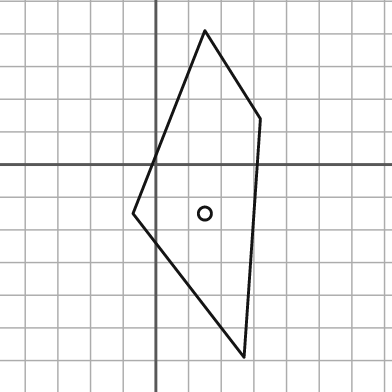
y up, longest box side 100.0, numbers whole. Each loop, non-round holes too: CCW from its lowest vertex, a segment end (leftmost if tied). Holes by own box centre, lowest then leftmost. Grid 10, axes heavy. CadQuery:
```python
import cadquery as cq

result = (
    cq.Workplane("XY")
    .moveTo(27.0, -59.0)
    .lineTo(32.0, 14.0)
    .lineTo(15.0, 41.0)
    .lineTo(-7.0, -15.0)
    .close()
    .moveTo(15.0, -15.0)
    .circle(2.0)
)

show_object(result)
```